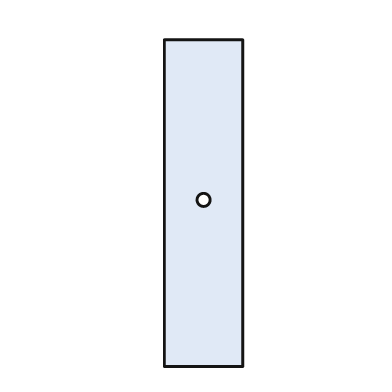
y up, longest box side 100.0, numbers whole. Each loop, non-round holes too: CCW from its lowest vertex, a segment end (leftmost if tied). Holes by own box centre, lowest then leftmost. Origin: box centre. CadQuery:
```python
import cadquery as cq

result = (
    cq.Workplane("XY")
    .moveTo(-12.0, -50.0)
    .lineTo(12.0, -50.0)
    .lineTo(12.0, 50.0)
    .lineTo(-12.0, 50.0)
    .close()
    .moveTo(0.0, 1.0)
    .circle(2.0)
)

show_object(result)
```